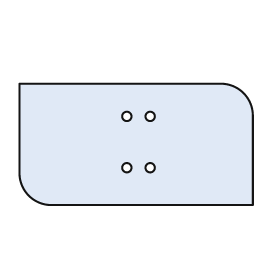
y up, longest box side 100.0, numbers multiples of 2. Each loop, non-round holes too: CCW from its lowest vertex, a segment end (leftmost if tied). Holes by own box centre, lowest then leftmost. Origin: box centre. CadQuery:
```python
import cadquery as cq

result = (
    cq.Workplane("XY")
    .moveTo(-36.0, -26.0)
    .lineTo(50.0, -26.0)
    .lineTo(50.0, 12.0)
    .threePointArc((46.0, 22.0), (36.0, 26.0))
    .lineTo(-50.0, 26.0)
    .lineTo(-50.0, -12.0)
    .threePointArc((-46.0, -22.0), (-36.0, -26.0))
    .close()
    .moveTo(-4.0, -10.0)
    .circle(2.0)
    .moveTo(6.0, -10.0)
    .circle(2.0)
    .moveTo(-4.0, 12.0)
    .circle(2.0)
    .moveTo(6.0, 12.0)
    .circle(2.0)
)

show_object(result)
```